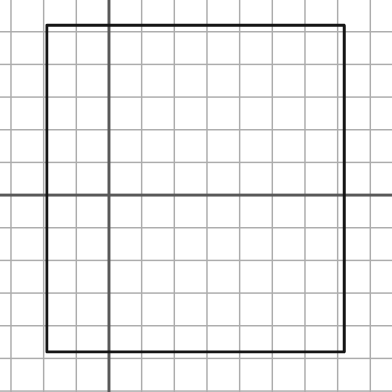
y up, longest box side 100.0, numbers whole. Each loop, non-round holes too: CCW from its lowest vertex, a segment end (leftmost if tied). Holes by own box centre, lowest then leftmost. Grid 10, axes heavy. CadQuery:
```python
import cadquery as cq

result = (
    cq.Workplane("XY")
    .moveTo(-19.0, -48.0)
    .lineTo(72.0, -48.0)
    .lineTo(72.0, 52.0)
    .lineTo(-19.0, 52.0)
    .close()
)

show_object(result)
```